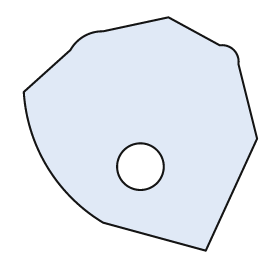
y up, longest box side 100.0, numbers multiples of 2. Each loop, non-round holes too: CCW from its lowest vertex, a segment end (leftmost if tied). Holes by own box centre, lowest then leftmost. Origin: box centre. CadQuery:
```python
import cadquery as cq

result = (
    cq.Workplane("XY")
    .moveTo(28.0, -50.0)
    .lineTo(50.0, -2.0)
    .lineTo(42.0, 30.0)
    .threePointArc((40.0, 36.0), (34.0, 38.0))
    .lineTo(12.0, 50.0)
    .lineTo(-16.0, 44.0)
    .threePointArc((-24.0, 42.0), (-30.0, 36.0))
    .lineTo(-50.0, 18.0)
    .threePointArc((-40.0, -14.0), (-16.0, -38.0))
    .close()
    .moveTo(0.0, -14.0)
    .circle(10.0)
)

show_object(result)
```